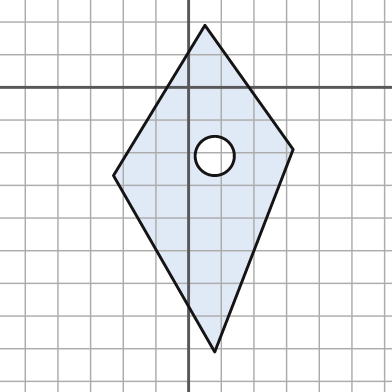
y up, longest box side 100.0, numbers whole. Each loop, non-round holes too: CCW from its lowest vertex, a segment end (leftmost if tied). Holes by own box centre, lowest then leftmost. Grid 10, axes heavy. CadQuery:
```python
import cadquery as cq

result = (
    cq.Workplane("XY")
    .moveTo(8.0, -81.0)
    .lineTo(32.0, -19.0)
    .lineTo(5.0, 19.0)
    .lineTo(-23.0, -27.0)
    .close()
    .moveTo(8.0, -21.0)
    .circle(6.0)
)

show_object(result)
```